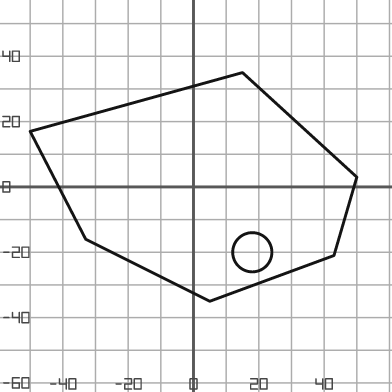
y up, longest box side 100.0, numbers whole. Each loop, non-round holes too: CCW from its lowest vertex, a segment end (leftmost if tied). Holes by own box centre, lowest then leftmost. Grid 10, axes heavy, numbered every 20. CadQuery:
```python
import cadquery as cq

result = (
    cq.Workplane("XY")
    .moveTo(5.0, -35.0)
    .lineTo(43.0, -21.0)
    .lineTo(50.0, 3.0)
    .lineTo(15.0, 35.0)
    .lineTo(-50.0, 17.0)
    .lineTo(-33.0, -16.0)
    .close()
    .moveTo(18.0, -20.0)
    .circle(6.0)
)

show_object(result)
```